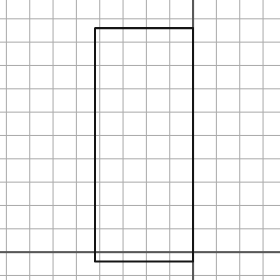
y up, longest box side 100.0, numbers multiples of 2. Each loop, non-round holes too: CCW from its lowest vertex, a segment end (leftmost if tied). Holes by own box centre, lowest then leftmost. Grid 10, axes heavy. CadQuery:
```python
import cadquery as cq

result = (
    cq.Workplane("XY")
    .moveTo(-42.0, -4.0)
    .lineTo(0.0, -4.0)
    .lineTo(0.0, 96.0)
    .lineTo(-42.0, 96.0)
    .close()
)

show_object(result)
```